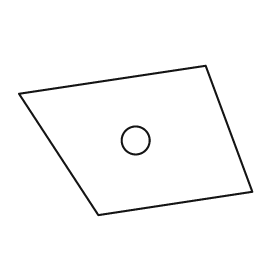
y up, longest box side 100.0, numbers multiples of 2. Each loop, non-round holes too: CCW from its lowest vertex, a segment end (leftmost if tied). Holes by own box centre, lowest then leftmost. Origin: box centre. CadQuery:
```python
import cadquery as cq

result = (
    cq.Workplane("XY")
    .moveTo(-16.0, -32.0)
    .lineTo(50.0, -22.0)
    .lineTo(30.0, 32.0)
    .lineTo(-50.0, 20.0)
    .close()
    .moveTo(0.0, 0.0)
    .circle(6.0)
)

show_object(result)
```